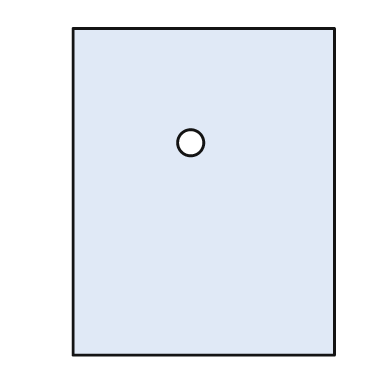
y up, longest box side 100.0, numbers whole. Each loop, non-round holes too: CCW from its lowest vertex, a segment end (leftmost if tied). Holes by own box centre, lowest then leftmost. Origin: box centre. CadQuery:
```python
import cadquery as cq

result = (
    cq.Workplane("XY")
    .moveTo(-40.0, -50.0)
    .lineTo(40.0, -50.0)
    .lineTo(40.0, 50.0)
    .lineTo(-40.0, 50.0)
    .close()
    .moveTo(-4.0, 15.0)
    .circle(4.0)
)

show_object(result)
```